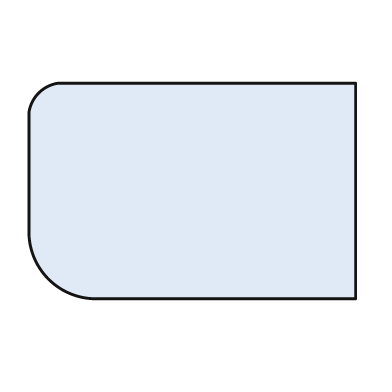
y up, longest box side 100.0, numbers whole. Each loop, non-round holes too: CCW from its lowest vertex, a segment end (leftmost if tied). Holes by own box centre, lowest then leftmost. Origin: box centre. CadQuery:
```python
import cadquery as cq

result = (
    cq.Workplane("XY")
    .moveTo(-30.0, -33.0)
    .lineTo(50.0, -33.0)
    .lineTo(50.0, 33.0)
    .lineTo(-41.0, 33.0)
    .threePointArc((-47.0, 30.0), (-50.0, 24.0))
    .lineTo(-50.0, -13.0)
    .threePointArc((-44.0, -27.0), (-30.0, -33.0))
    .close()
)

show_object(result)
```